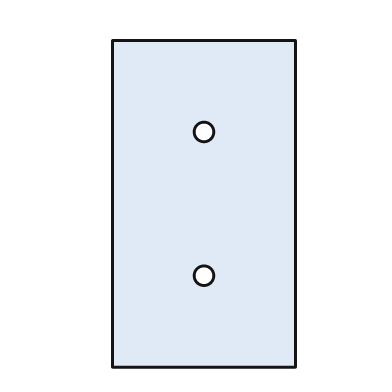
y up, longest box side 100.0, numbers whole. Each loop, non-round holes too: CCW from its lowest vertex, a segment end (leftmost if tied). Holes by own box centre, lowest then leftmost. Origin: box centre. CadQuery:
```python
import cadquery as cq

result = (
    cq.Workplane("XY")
    .moveTo(-28.0, -50.0)
    .lineTo(28.0, -50.0)
    .lineTo(28.0, 50.0)
    .lineTo(-28.0, 50.0)
    .close()
    .moveTo(0.0, -22.0)
    .circle(3.0)
    .moveTo(0.0, 22.0)
    .circle(3.0)
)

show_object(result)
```